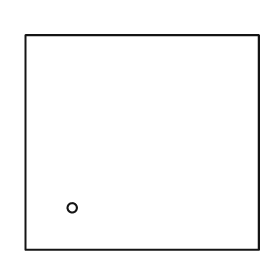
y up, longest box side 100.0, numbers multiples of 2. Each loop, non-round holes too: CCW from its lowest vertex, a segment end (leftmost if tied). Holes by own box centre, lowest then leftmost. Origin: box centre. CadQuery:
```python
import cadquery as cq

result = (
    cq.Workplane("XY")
    .moveTo(-50.0, -46.0)
    .lineTo(50.0, -46.0)
    .lineTo(50.0, 46.0)
    .lineTo(-50.0, 46.0)
    .close()
    .moveTo(-30.0, -28.0)
    .circle(2.0)
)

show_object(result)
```